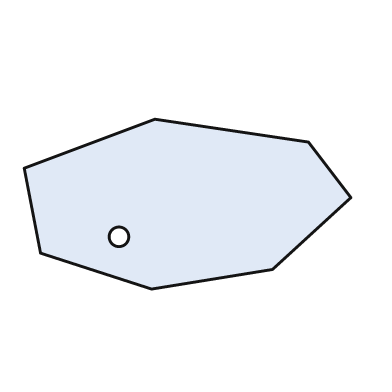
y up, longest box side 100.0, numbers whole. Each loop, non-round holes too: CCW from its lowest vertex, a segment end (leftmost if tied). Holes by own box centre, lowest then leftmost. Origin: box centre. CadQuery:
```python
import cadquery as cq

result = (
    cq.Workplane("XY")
    .moveTo(-11.0, -26.0)
    .lineTo(26.0, -20.0)
    .lineTo(50.0, 2.0)
    .lineTo(37.0, 19.0)
    .lineTo(-10.0, 26.0)
    .lineTo(-50.0, 11.0)
    .lineTo(-45.0, -15.0)
    .close()
    .moveTo(-21.0, -10.0)
    .circle(3.0)
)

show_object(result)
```